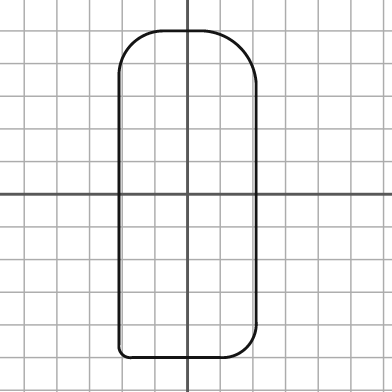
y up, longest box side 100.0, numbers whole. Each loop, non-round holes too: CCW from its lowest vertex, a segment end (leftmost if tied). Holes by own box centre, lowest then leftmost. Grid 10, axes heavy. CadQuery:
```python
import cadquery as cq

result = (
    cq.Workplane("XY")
    .moveTo(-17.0, -50.0)
    .lineTo(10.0, -50.0)
    .threePointArc((18.0, -47.0), (21.0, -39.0))
    .lineTo(21.0, 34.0)
    .threePointArc((16.0, 45.0), (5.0, 50.0))
    .lineTo(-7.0, 50.0)
    .threePointArc((-17.0, 46.0), (-21.0, 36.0))
    .lineTo(-21.0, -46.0)
    .threePointArc((-20.0, -49.0), (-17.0, -50.0))
    .close()
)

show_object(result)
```